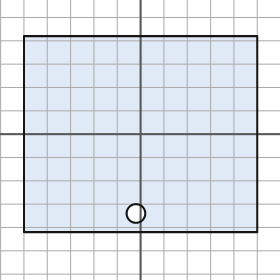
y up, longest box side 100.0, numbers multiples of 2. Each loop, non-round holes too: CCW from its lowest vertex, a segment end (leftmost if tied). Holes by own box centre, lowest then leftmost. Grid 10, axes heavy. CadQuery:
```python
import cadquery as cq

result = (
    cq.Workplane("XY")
    .moveTo(-50.0, -42.0)
    .lineTo(50.0, -42.0)
    .lineTo(50.0, 42.0)
    .lineTo(-50.0, 42.0)
    .close()
    .moveTo(-2.0, -34.0)
    .circle(4.0)
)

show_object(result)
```